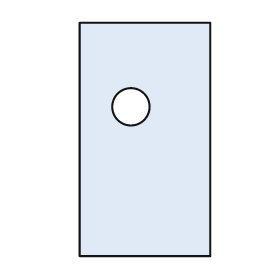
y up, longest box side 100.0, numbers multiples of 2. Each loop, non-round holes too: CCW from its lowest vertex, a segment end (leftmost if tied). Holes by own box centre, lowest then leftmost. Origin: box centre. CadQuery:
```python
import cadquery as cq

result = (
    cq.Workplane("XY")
    .moveTo(-28.0, -50.0)
    .lineTo(28.0, -50.0)
    .lineTo(28.0, 50.0)
    .lineTo(-28.0, 50.0)
    .close()
    .moveTo(-6.0, 14.0)
    .circle(8.0)
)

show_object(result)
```